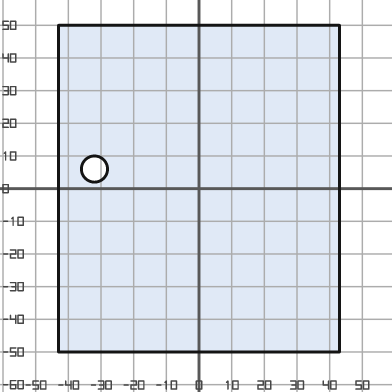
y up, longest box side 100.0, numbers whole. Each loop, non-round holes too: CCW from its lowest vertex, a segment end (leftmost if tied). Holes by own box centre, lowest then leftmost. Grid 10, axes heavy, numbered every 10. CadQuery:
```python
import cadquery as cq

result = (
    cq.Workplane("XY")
    .moveTo(-43.0, -50.0)
    .lineTo(43.0, -50.0)
    .lineTo(43.0, 50.0)
    .lineTo(-43.0, 50.0)
    .close()
    .moveTo(-32.0, 6.0)
    .circle(4.0)
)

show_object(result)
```